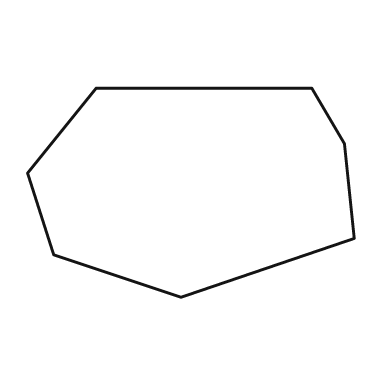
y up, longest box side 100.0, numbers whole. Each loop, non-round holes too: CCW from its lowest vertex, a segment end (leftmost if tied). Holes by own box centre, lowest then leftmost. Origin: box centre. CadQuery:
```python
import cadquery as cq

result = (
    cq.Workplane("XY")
    .moveTo(-3.0, -32.0)
    .lineTo(50.0, -14.0)
    .lineTo(47.0, 15.0)
    .lineTo(37.0, 32.0)
    .lineTo(-29.0, 32.0)
    .lineTo(-50.0, 6.0)
    .lineTo(-42.0, -19.0)
    .close()
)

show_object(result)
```